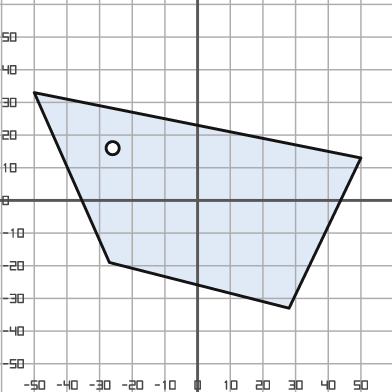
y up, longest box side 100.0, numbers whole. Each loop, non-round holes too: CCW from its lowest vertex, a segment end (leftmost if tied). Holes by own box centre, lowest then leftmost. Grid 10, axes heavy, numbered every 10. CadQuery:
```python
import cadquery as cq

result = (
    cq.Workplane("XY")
    .moveTo(28.0, -33.0)
    .lineTo(50.0, 13.0)
    .lineTo(-50.0, 33.0)
    .lineTo(-27.0, -19.0)
    .close()
    .moveTo(-26.0, 16.0)
    .circle(2.0)
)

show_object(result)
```